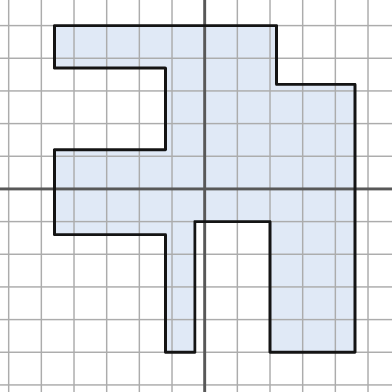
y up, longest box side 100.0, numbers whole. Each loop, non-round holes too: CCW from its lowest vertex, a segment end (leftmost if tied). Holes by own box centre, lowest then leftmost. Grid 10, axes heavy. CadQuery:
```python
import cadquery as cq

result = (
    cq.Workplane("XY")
    .moveTo(-12.0, -50.0)
    .lineTo(-3.0, -50.0)
    .lineTo(-3.0, -10.0)
    .lineTo(20.0, -10.0)
    .lineTo(20.0, -50.0)
    .lineTo(46.0, -50.0)
    .lineTo(46.0, 32.0)
    .lineTo(22.0, 32.0)
    .lineTo(22.0, 50.0)
    .lineTo(-46.0, 50.0)
    .lineTo(-46.0, 37.0)
    .lineTo(-12.0, 37.0)
    .lineTo(-12.0, 12.0)
    .lineTo(-46.0, 12.0)
    .lineTo(-46.0, -14.0)
    .lineTo(-12.0, -14.0)
    .close()
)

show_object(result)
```